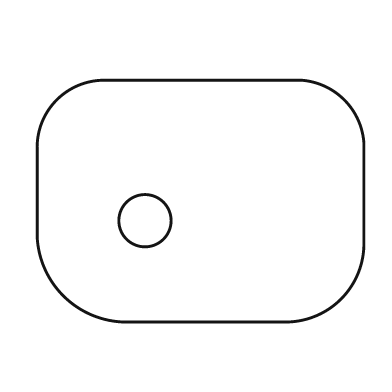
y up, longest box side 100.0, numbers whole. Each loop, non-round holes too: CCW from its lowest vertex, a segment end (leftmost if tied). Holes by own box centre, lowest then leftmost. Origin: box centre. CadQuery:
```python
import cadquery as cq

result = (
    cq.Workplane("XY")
    .moveTo(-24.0, -37.0)
    .lineTo(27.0, -37.0)
    .threePointArc((43.0, -30.0), (50.0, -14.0))
    .lineTo(50.0, 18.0)
    .threePointArc((44.0, 31.0), (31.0, 37.0))
    .lineTo(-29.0, 37.0)
    .threePointArc((-44.0, 31.0), (-50.0, 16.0))
    .lineTo(-50.0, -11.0)
    .threePointArc((-42.0, -29.0), (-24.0, -37.0))
    .close()
    .moveTo(-17.0, -6.0)
    .circle(8.0)
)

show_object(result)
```